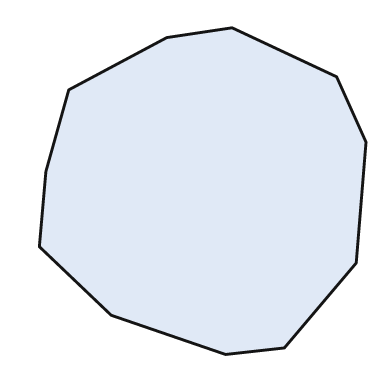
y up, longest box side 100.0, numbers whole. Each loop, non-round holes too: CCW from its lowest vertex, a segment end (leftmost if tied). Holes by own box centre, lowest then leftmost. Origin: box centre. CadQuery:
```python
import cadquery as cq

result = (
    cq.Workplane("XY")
    .moveTo(7.0, -50.0)
    .lineTo(25.0, -48.0)
    .lineTo(47.0, -22.0)
    .lineTo(50.0, 15.0)
    .lineTo(41.0, 35.0)
    .lineTo(9.0, 50.0)
    .lineTo(-11.0, 47.0)
    .lineTo(-41.0, 31.0)
    .lineTo(-48.0, 6.0)
    .lineTo(-50.0, -17.0)
    .lineTo(-28.0, -38.0)
    .close()
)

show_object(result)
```